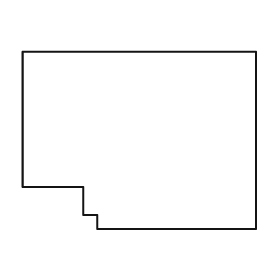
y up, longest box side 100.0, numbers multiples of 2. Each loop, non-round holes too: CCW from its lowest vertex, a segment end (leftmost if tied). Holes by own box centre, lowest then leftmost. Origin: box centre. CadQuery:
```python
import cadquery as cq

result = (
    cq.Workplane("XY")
    .moveTo(-18.0, -38.0)
    .lineTo(50.0, -38.0)
    .lineTo(50.0, 38.0)
    .lineTo(-50.0, 38.0)
    .lineTo(-50.0, -20.0)
    .lineTo(-24.0, -20.0)
    .lineTo(-24.0, -32.0)
    .lineTo(-18.0, -32.0)
    .close()
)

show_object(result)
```